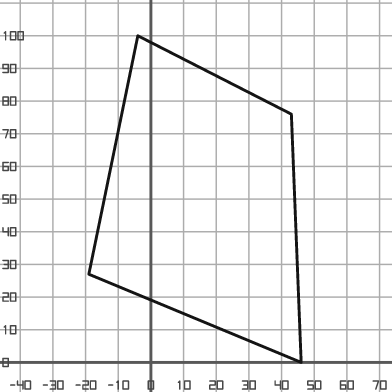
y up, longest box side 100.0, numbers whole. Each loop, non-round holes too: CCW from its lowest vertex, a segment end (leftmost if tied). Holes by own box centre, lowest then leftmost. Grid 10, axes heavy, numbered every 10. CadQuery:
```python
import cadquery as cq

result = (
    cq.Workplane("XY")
    .moveTo(46.0, 0.0)
    .lineTo(43.0, 76.0)
    .lineTo(-4.0, 100.0)
    .lineTo(-19.0, 27.0)
    .close()
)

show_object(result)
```